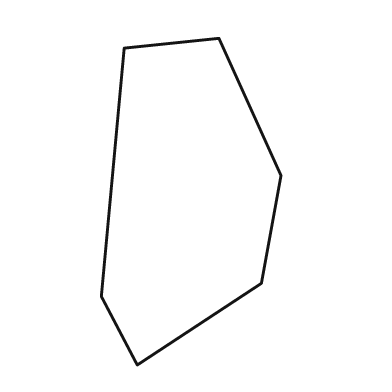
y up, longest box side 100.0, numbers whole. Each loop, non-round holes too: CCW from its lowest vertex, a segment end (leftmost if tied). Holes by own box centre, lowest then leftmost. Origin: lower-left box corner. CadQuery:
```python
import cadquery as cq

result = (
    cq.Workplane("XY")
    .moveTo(11.0, 0.0)
    .lineTo(49.0, 25.0)
    .lineTo(55.0, 58.0)
    .lineTo(36.0, 100.0)
    .lineTo(7.0, 97.0)
    .lineTo(0.0, 21.0)
    .close()
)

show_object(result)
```